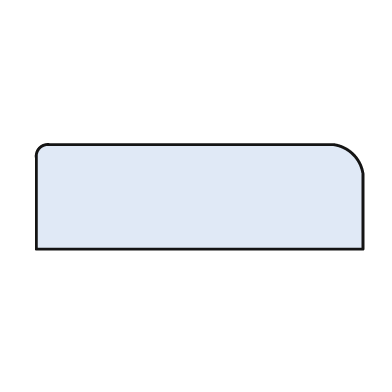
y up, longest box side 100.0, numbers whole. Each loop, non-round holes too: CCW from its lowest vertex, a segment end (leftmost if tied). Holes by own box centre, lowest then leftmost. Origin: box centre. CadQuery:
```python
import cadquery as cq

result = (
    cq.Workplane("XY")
    .moveTo(-50.0, -16.0)
    .lineTo(50.0, -16.0)
    .lineTo(50.0, 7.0)
    .threePointArc((47.0, 13.0), (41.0, 16.0))
    .lineTo(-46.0, 16.0)
    .threePointArc((-49.0, 15.0), (-50.0, 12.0))
    .close()
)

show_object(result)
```